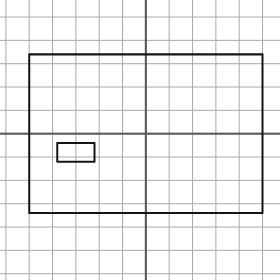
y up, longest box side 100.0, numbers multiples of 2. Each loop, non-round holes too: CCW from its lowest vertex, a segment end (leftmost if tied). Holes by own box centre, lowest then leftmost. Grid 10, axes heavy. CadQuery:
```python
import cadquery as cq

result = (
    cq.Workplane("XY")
    .moveTo(-50.0, -34.0)
    .lineTo(50.0, -34.0)
    .lineTo(50.0, 34.0)
    .lineTo(-50.0, 34.0)
    .close()
    .moveTo(-38.0, -12.0)
    .lineTo(-22.0, -12.0)
    .lineTo(-22.0, -4.0)
    .lineTo(-38.0, -4.0)
    .close()
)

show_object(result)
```